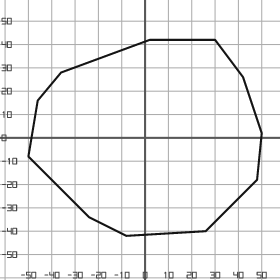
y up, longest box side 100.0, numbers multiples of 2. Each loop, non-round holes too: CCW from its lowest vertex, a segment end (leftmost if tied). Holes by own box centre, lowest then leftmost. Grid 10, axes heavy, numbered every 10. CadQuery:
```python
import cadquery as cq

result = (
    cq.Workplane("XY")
    .moveTo(-8.0, -42.0)
    .lineTo(26.0, -40.0)
    .lineTo(48.0, -18.0)
    .lineTo(50.0, 2.0)
    .lineTo(42.0, 26.0)
    .lineTo(30.0, 42.0)
    .lineTo(2.0, 42.0)
    .lineTo(-36.0, 28.0)
    .lineTo(-46.0, 16.0)
    .lineTo(-50.0, -8.0)
    .lineTo(-24.0, -34.0)
    .close()
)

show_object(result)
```